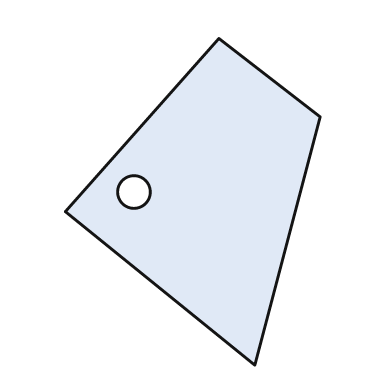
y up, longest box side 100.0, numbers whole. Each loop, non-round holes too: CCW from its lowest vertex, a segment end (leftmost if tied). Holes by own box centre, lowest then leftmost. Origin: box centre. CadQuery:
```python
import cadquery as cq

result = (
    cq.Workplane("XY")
    .moveTo(19.0, -50.0)
    .lineTo(39.0, 26.0)
    .lineTo(8.0, 50.0)
    .lineTo(-39.0, -3.0)
    .close()
    .moveTo(-18.0, 3.0)
    .circle(5.0)
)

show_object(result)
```